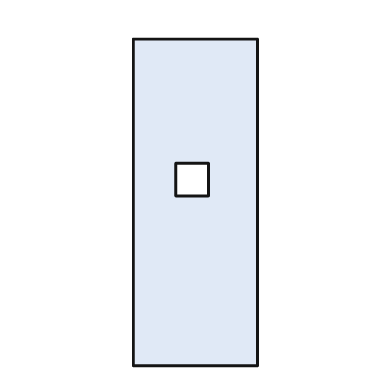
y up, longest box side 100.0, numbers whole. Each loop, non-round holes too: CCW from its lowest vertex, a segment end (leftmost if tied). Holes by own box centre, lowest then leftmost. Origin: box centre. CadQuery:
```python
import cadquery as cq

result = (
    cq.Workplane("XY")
    .moveTo(-19.0, -50.0)
    .lineTo(19.0, -50.0)
    .lineTo(19.0, 50.0)
    .lineTo(-19.0, 50.0)
    .close()
    .moveTo(-6.0, 2.0)
    .lineTo(4.0, 2.0)
    .lineTo(4.0, 12.0)
    .lineTo(-6.0, 12.0)
    .close()
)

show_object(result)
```